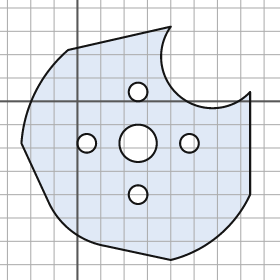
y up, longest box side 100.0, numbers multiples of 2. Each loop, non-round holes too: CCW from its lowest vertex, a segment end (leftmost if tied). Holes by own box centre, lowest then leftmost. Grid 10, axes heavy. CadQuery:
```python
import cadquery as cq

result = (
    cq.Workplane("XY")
    .moveTo(40.0, -68.0)
    .threePointArc((60.0, -58.0), (74.0, -40.0))
    .lineTo(74.0, 4.0)
    .threePointArc((44.0, 2.0), (40.0, 32.0))
    .lineTo(-4.0, 22.0)
    .threePointArc((-18.0, 4.0), (-24.0, -18.0))
    .lineTo(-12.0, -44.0)
    .threePointArc((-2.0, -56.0), (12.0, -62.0))
    .close()
    .moveTo(26.0, -40.0)
    .circle(4.0)
    .moveTo(4.0, -18.0)
    .circle(4.0)
    .moveTo(26.0, -18.0)
    .circle(8.0)
    .moveTo(48.0, -18.0)
    .circle(4.0)
    .moveTo(26.0, 4.0)
    .circle(4.0)
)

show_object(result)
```